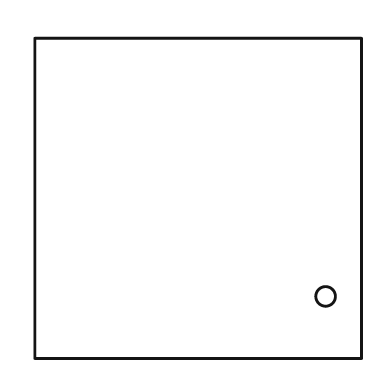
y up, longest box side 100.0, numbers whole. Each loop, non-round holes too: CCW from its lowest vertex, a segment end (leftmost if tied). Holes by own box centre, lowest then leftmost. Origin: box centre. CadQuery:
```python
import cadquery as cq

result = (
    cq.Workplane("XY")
    .moveTo(-50.0, -49.0)
    .lineTo(50.0, -49.0)
    .lineTo(50.0, 49.0)
    .lineTo(-50.0, 49.0)
    .close()
    .moveTo(39.0, -30.0)
    .circle(3.0)
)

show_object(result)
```